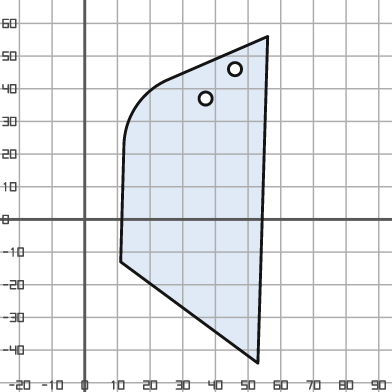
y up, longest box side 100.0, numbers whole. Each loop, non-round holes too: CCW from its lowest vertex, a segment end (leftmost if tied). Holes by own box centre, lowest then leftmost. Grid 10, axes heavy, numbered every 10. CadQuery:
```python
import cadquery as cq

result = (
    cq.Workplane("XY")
    .moveTo(53.0, -44.0)
    .lineTo(56.0, 56.0)
    .lineTo(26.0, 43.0)
    .threePointArc((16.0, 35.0), (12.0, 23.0))
    .lineTo(11.0, -13.0)
    .close()
    .moveTo(37.0, 37.0)
    .circle(2.0)
    .moveTo(46.0, 46.0)
    .circle(2.0)
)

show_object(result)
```